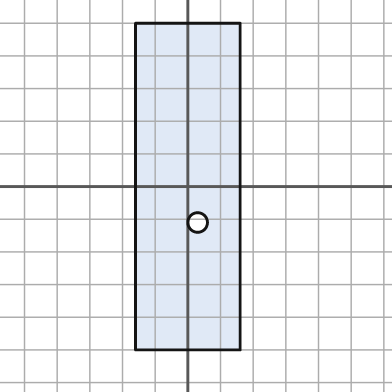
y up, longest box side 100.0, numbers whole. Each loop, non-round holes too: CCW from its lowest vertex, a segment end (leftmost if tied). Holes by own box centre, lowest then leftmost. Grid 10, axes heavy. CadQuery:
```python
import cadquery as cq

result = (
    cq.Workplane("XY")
    .moveTo(-16.0, -50.0)
    .lineTo(16.0, -50.0)
    .lineTo(16.0, 50.0)
    .lineTo(-16.0, 50.0)
    .close()
    .moveTo(3.0, -11.0)
    .circle(3.0)
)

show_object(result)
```